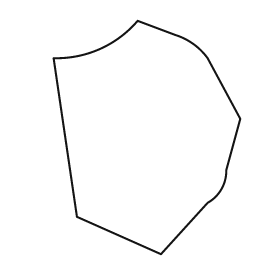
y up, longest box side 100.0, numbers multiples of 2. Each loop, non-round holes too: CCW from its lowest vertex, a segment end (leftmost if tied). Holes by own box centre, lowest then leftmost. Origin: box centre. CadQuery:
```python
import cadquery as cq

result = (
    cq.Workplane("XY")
    .moveTo(6.0, -50.0)
    .lineTo(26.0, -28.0)
    .threePointArc((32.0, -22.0), (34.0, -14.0))
    .lineTo(40.0, 8.0)
    .lineTo(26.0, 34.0)
    .threePointArc((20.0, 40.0), (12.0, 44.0))
    .lineTo(-4.0, 50.0)
    .threePointArc((-20.0, 38.0), (-40.0, 34.0))
    .lineTo(-30.0, -34.0)
    .close()
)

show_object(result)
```